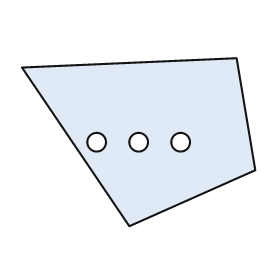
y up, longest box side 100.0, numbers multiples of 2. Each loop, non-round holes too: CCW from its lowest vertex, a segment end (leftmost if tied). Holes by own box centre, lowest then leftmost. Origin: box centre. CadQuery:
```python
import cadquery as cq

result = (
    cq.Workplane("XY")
    .moveTo(-4.0, -36.0)
    .lineTo(50.0, -12.0)
    .lineTo(42.0, 36.0)
    .lineTo(-50.0, 32.0)
    .close()
    .moveTo(-18.0, 0.0)
    .circle(4.0)
    .moveTo(0.0, 0.0)
    .circle(4.0)
    .moveTo(18.0, 0.0)
    .circle(4.0)
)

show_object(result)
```